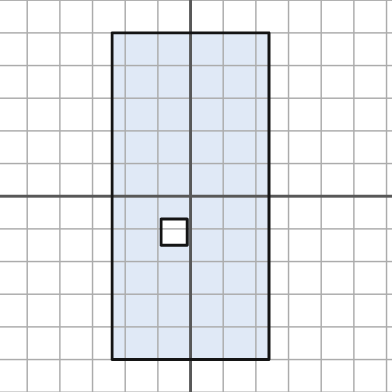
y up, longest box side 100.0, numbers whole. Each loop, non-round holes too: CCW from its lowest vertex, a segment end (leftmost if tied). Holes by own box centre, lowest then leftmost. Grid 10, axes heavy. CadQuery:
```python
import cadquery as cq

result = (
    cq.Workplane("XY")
    .moveTo(-24.0, -50.0)
    .lineTo(24.0, -50.0)
    .lineTo(24.0, 50.0)
    .lineTo(-24.0, 50.0)
    .close()
    .moveTo(-9.0, -15.0)
    .lineTo(-1.0, -15.0)
    .lineTo(-1.0, -7.0)
    .lineTo(-9.0, -7.0)
    .close()
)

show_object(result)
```